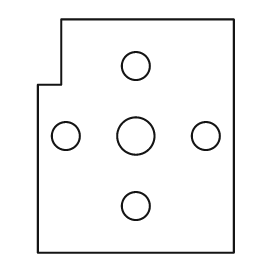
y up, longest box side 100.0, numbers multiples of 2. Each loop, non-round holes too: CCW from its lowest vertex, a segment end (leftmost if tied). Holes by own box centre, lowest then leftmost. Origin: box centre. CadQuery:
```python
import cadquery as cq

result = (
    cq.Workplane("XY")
    .moveTo(-42.0, -50.0)
    .lineTo(42.0, -50.0)
    .lineTo(42.0, 50.0)
    .lineTo(-32.0, 50.0)
    .lineTo(-32.0, 22.0)
    .lineTo(-42.0, 22.0)
    .close()
    .moveTo(0.0, -30.0)
    .circle(6.0)
    .moveTo(-30.0, 0.0)
    .circle(6.0)
    .moveTo(0.0, 0.0)
    .circle(8.0)
    .moveTo(30.0, 0.0)
    .circle(6.0)
    .moveTo(0.0, 30.0)
    .circle(6.0)
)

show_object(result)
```